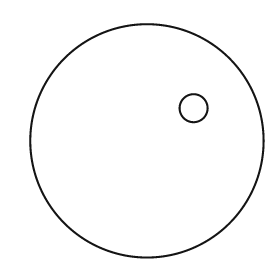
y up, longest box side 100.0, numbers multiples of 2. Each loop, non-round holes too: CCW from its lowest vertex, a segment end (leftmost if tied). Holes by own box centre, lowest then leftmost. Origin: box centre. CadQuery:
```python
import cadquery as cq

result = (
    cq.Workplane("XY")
    .moveTo(0.0, 0.0)
    .circle(50.0)
    .moveTo(20.0, 14.0)
    .circle(6.0)
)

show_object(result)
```